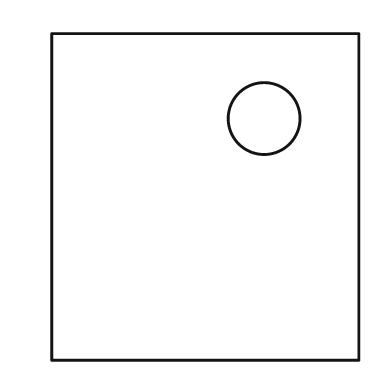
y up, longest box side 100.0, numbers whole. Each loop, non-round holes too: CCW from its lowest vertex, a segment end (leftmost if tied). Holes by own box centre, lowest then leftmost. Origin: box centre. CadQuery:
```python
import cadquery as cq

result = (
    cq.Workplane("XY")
    .moveTo(-47.0, -50.0)
    .lineTo(47.0, -50.0)
    .lineTo(47.0, 50.0)
    .lineTo(-47.0, 50.0)
    .close()
    .moveTo(18.0, 24.0)
    .circle(11.0)
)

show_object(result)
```